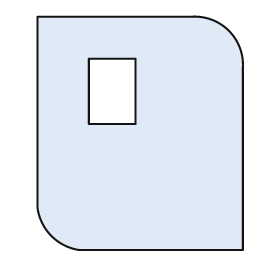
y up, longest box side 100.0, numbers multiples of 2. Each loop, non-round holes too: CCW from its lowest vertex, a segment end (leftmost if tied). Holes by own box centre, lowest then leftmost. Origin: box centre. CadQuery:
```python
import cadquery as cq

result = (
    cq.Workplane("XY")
    .moveTo(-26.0, -50.0)
    .lineTo(44.0, -50.0)
    .lineTo(44.0, 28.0)
    .threePointArc((38.0, 44.0), (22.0, 50.0))
    .lineTo(-44.0, 50.0)
    .lineTo(-44.0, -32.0)
    .threePointArc((-38.0, -44.0), (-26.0, -50.0))
    .close()
    .moveTo(-22.0, 4.0)
    .lineTo(-2.0, 4.0)
    .lineTo(-2.0, 32.0)
    .lineTo(-22.0, 32.0)
    .close()
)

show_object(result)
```